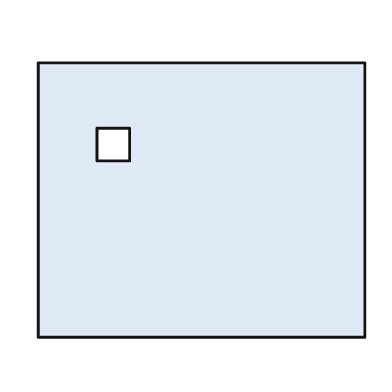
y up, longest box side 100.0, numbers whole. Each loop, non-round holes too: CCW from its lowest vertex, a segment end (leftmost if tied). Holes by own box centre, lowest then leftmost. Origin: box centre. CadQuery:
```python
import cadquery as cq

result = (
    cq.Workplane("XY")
    .moveTo(-50.0, -42.0)
    .lineTo(50.0, -42.0)
    .lineTo(50.0, 42.0)
    .lineTo(-50.0, 42.0)
    .close()
    .moveTo(-32.0, 12.0)
    .lineTo(-22.0, 12.0)
    .lineTo(-22.0, 22.0)
    .lineTo(-32.0, 22.0)
    .close()
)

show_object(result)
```